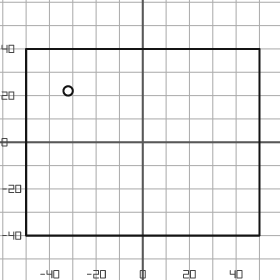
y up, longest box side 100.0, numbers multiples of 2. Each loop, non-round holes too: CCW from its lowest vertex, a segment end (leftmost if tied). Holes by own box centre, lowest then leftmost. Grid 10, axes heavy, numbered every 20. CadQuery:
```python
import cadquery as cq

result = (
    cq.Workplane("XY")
    .moveTo(-50.0, -40.0)
    .lineTo(50.0, -40.0)
    .lineTo(50.0, 40.0)
    .lineTo(-50.0, 40.0)
    .close()
    .moveTo(-32.0, 22.0)
    .circle(2.0)
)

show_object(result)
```